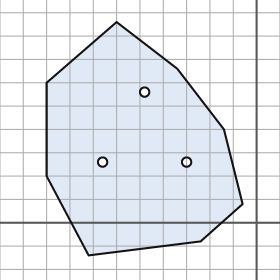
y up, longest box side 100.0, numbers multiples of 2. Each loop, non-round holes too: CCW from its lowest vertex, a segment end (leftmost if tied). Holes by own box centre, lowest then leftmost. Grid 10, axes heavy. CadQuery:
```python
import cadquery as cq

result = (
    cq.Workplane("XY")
    .moveTo(-72.0, -14.0)
    .lineTo(-24.0, -8.0)
    .lineTo(-6.0, 8.0)
    .lineTo(-14.0, 40.0)
    .lineTo(-34.0, 66.0)
    .lineTo(-60.0, 86.0)
    .lineTo(-90.0, 60.0)
    .lineTo(-90.0, 20.0)
    .close()
    .moveTo(-66.0, 26.0)
    .circle(2.0)
    .moveTo(-30.0, 26.0)
    .circle(2.0)
    .moveTo(-48.0, 56.0)
    .circle(2.0)
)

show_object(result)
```